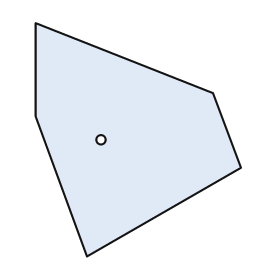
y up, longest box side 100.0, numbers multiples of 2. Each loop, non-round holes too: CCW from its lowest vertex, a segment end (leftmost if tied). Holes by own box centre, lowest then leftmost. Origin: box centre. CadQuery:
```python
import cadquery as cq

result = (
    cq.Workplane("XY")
    .moveTo(-22.0, -50.0)
    .lineTo(44.0, -12.0)
    .lineTo(32.0, 20.0)
    .lineTo(-44.0, 50.0)
    .lineTo(-44.0, 10.0)
    .close()
    .moveTo(-16.0, 0.0)
    .circle(2.0)
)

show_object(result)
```